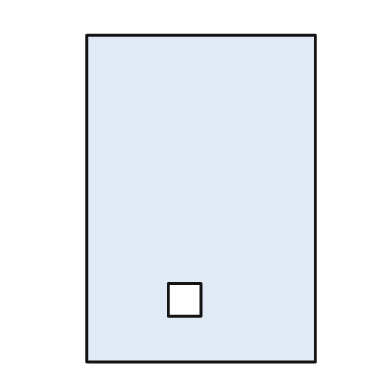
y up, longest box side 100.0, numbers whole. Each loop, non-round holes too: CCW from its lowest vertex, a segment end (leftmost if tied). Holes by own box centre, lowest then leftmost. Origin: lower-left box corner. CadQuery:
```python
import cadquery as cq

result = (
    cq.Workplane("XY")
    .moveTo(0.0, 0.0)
    .lineTo(70.0, 0.0)
    .lineTo(70.0, 100.0)
    .lineTo(0.0, 100.0)
    .close()
    .moveTo(25.0, 14.0)
    .lineTo(35.0, 14.0)
    .lineTo(35.0, 24.0)
    .lineTo(25.0, 24.0)
    .close()
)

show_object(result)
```